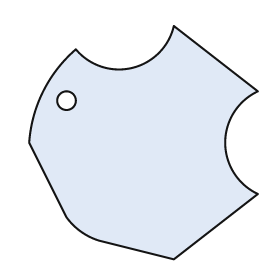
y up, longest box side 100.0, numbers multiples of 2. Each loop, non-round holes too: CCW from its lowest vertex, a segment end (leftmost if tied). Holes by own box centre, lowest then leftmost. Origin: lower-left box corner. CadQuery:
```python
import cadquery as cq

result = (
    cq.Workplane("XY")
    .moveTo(62.0, 0.0)
    .lineTo(98.0, 28.0)
    .threePointArc((84.0, 50.0), (98.0, 72.0))
    .lineTo(62.0, 100.0)
    .threePointArc((44.0, 82.0), (20.0, 90.0))
    .threePointArc((6.0, 72.0), (0.0, 50.0))
    .lineTo(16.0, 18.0)
    .threePointArc((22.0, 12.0), (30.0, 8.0))
    .close()
    .moveTo(16.0, 68.0)
    .circle(4.0)
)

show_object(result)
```